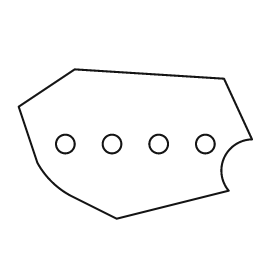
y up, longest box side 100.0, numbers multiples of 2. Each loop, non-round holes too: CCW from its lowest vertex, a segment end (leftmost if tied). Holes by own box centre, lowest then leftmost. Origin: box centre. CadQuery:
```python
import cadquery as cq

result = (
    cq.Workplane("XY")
    .moveTo(-8.0, -32.0)
    .lineTo(40.0, -20.0)
    .threePointArc((38.0, -6.0), (50.0, 2.0))
    .lineTo(38.0, 28.0)
    .lineTo(-26.0, 32.0)
    .lineTo(-50.0, 16.0)
    .lineTo(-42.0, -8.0)
    .threePointArc((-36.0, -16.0), (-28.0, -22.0))
    .close()
    .moveTo(-30.0, 0.0)
    .circle(4.0)
    .moveTo(-10.0, 0.0)
    .circle(4.0)
    .moveTo(10.0, 0.0)
    .circle(4.0)
    .moveTo(30.0, 0.0)
    .circle(4.0)
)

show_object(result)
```